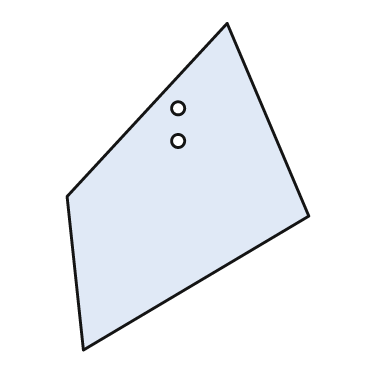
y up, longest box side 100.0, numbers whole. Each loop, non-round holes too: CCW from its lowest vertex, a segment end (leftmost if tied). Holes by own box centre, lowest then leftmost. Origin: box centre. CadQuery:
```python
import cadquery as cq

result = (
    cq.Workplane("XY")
    .moveTo(-32.0, -50.0)
    .lineTo(37.0, -9.0)
    .lineTo(12.0, 50.0)
    .lineTo(-37.0, -3.0)
    .close()
    .moveTo(-3.0, 14.0)
    .circle(2.0)
    .moveTo(-3.0, 24.0)
    .circle(2.0)
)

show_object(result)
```